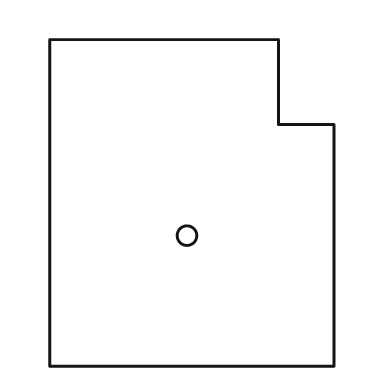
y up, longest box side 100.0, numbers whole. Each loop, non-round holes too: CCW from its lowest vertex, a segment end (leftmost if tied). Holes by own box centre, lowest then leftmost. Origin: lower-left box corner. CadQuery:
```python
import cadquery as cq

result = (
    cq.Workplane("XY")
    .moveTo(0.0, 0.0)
    .lineTo(87.0, 0.0)
    .lineTo(87.0, 74.0)
    .lineTo(70.0, 74.0)
    .lineTo(70.0, 100.0)
    .lineTo(0.0, 100.0)
    .close()
    .moveTo(42.0, 40.0)
    .circle(3.0)
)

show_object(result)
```